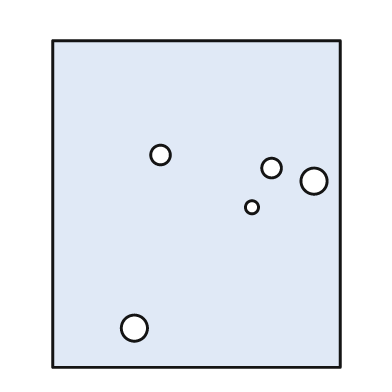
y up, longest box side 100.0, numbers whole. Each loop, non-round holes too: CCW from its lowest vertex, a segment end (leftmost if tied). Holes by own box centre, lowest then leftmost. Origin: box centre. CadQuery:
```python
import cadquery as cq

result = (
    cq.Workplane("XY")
    .moveTo(-44.0, -50.0)
    .lineTo(44.0, -50.0)
    .lineTo(44.0, 50.0)
    .lineTo(-44.0, 50.0)
    .close()
    .moveTo(-19.0, -38.0)
    .circle(4.0)
    .moveTo(17.0, -1.0)
    .circle(2.0)
    .moveTo(36.0, 7.0)
    .circle(4.0)
    .moveTo(23.0, 11.0)
    .circle(3.0)
    .moveTo(-11.0, 15.0)
    .circle(3.0)
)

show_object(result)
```